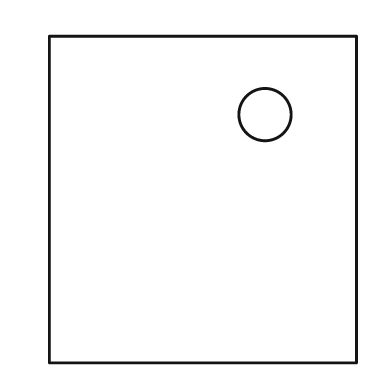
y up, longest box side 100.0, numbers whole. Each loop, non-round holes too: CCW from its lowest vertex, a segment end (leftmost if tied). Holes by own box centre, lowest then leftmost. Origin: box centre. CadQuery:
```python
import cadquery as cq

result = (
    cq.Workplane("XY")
    .moveTo(-47.0, -50.0)
    .lineTo(47.0, -50.0)
    .lineTo(47.0, 50.0)
    .lineTo(-47.0, 50.0)
    .close()
    .moveTo(19.0, 26.0)
    .circle(8.0)
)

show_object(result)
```